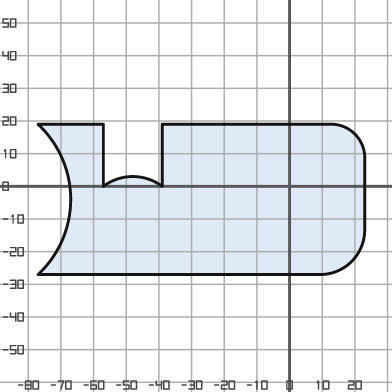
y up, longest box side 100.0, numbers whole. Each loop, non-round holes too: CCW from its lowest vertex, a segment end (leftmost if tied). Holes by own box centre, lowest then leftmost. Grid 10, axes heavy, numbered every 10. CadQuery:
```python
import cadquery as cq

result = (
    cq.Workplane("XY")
    .moveTo(-77.0, -27.0)
    .lineTo(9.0, -27.0)
    .threePointArc((19.0, -23.0), (23.0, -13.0))
    .lineTo(23.0, 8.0)
    .threePointArc((20.0, 16.0), (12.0, 19.0))
    .lineTo(-39.0, 19.0)
    .lineTo(-39.0, 0.0)
    .threePointArc((-48.0, 3.0), (-57.0, 0.0))
    .lineTo(-57.0, 19.0)
    .lineTo(-77.0, 19.0)
    .threePointArc((-67.0, -4.0), (-77.0, -27.0))
    .close()
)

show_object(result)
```